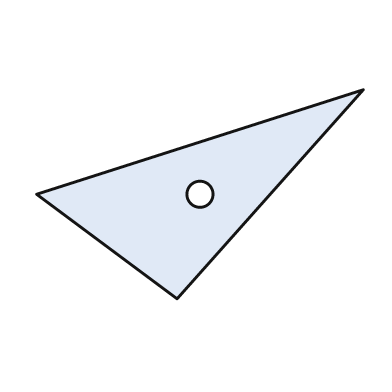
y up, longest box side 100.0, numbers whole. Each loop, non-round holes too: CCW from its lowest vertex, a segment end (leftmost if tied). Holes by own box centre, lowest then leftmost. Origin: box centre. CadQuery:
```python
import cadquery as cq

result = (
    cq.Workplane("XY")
    .moveTo(-7.0, -32.0)
    .lineTo(50.0, 32.0)
    .lineTo(-50.0, 0.0)
    .close()
    .moveTo(0.0, 0.0)
    .circle(4.0)
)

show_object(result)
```